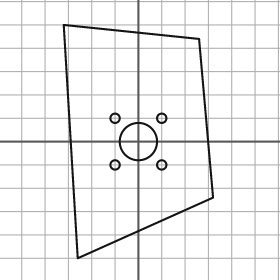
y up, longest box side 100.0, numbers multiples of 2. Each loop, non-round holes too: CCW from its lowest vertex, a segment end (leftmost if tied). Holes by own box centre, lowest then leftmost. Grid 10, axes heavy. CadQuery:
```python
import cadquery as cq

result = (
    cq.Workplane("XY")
    .moveTo(-26.0, -50.0)
    .lineTo(32.0, -24.0)
    .lineTo(26.0, 44.0)
    .lineTo(-32.0, 50.0)
    .close()
    .moveTo(-10.0, -10.0)
    .circle(2.0)
    .moveTo(10.0, -10.0)
    .circle(2.0)
    .moveTo(0.0, 0.0)
    .circle(8.0)
    .moveTo(-10.0, 10.0)
    .circle(2.0)
    .moveTo(10.0, 10.0)
    .circle(2.0)
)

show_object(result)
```